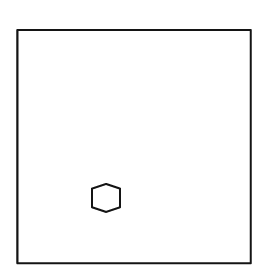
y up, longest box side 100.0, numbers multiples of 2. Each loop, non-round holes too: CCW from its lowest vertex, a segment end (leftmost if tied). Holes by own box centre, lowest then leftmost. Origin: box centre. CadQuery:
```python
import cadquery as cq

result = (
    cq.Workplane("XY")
    .moveTo(-50.0, -50.0)
    .lineTo(50.0, -50.0)
    .lineTo(50.0, 50.0)
    .lineTo(-50.0, 50.0)
    .close()
    .moveTo(-12.0, -28.0)
    .lineTo(-6.0, -26.0)
    .lineTo(-6.0, -18.0)
    .lineTo(-12.0, -16.0)
    .lineTo(-18.0, -18.0)
    .lineTo(-18.0, -26.0)
    .close()
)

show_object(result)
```